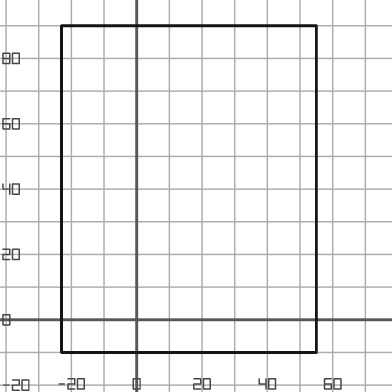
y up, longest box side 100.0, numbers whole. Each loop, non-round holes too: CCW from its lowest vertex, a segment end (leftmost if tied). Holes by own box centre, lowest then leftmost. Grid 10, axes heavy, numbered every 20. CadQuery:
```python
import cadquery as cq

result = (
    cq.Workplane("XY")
    .moveTo(-23.0, -10.0)
    .lineTo(55.0, -10.0)
    .lineTo(55.0, 90.0)
    .lineTo(-23.0, 90.0)
    .close()
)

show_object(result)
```